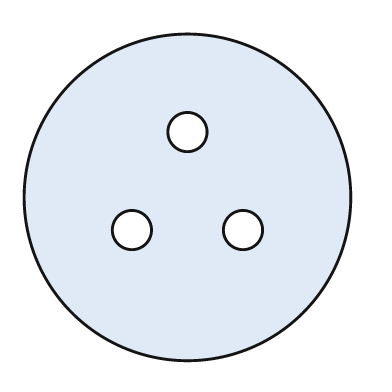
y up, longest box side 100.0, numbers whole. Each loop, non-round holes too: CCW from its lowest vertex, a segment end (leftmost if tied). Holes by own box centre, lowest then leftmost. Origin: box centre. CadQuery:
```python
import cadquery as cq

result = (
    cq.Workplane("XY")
    .moveTo(0.0, 0.0)
    .circle(50.0)
    .moveTo(-17.0, -10.0)
    .circle(6.0)
    .moveTo(17.0, -10.0)
    .circle(6.0)
    .moveTo(0.0, 20.0)
    .circle(6.0)
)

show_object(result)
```